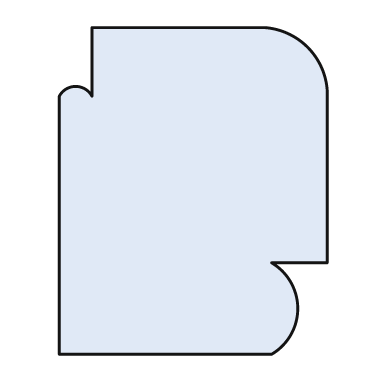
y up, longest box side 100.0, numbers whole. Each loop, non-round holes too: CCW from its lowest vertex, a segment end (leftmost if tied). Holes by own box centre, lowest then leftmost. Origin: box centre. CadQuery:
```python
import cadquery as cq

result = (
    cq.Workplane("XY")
    .moveTo(-41.0, -50.0)
    .lineTo(24.0, -50.0)
    .threePointArc((32.0, -36.0), (24.0, -22.0))
    .lineTo(41.0, -22.0)
    .lineTo(41.0, 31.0)
    .threePointArc((35.0, 44.0), (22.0, 50.0))
    .lineTo(-31.0, 50.0)
    .lineTo(-31.0, 29.0)
    .threePointArc((-36.0, 32.0), (-41.0, 29.0))
    .close()
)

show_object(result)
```